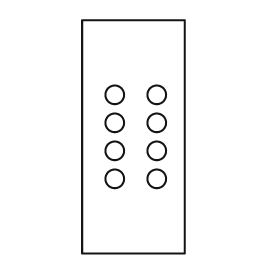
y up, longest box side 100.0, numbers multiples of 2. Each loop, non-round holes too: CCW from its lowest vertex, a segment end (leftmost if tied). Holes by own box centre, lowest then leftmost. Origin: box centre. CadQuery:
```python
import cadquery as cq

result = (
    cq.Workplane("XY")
    .moveTo(-22.0, -50.0)
    .lineTo(22.0, -50.0)
    .lineTo(22.0, 50.0)
    .lineTo(-22.0, 50.0)
    .close()
    .moveTo(-8.0, -18.0)
    .circle(4.0)
    .moveTo(10.0, -18.0)
    .circle(4.0)
    .moveTo(-8.0, -6.0)
    .circle(4.0)
    .moveTo(10.0, -6.0)
    .circle(4.0)
    .moveTo(-8.0, 6.0)
    .circle(4.0)
    .moveTo(10.0, 6.0)
    .circle(4.0)
    .moveTo(-8.0, 18.0)
    .circle(4.0)
    .moveTo(10.0, 18.0)
    .circle(4.0)
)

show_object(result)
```